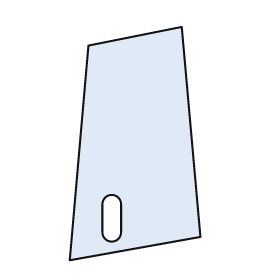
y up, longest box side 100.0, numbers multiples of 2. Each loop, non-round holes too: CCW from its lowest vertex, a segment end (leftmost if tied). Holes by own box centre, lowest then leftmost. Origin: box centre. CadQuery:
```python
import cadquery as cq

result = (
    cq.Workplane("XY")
    .moveTo(-28.0, -50.0)
    .lineTo(28.0, -40.0)
    .lineTo(20.0, 50.0)
    .lineTo(-20.0, 42.0)
    .close()
    .moveTo(-14.0, -38.0)
    .threePointArc((-10.0, -42.0), (-6.0, -38.0))
    .lineTo(-6.0, -26.0)
    .threePointArc((-10.0, -22.0), (-14.0, -26.0))
    .close()
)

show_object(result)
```